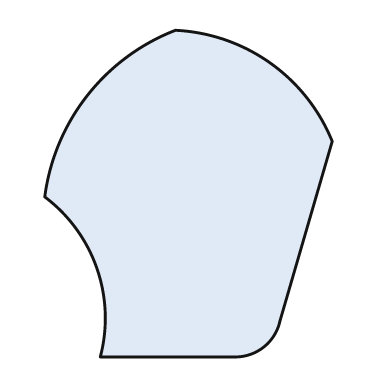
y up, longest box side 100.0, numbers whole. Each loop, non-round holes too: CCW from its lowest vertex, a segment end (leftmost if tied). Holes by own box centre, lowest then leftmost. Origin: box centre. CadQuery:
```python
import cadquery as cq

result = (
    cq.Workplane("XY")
    .moveTo(-27.0, -50.0)
    .lineTo(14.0, -50.0)
    .threePointArc((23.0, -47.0), (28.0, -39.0))
    .lineTo(44.0, 16.0)
    .threePointArc((25.0, 40.0), (-4.0, 50.0))
    .threePointArc((-31.0, 30.0), (-44.0, -1.0))
    .threePointArc((-28.0, -23.0), (-27.0, -50.0))
    .close()
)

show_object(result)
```